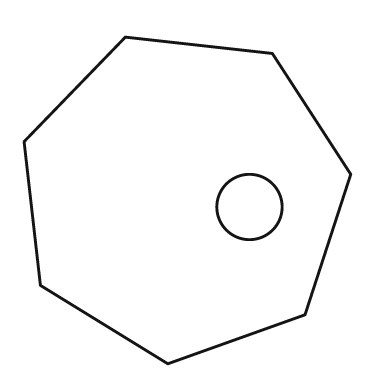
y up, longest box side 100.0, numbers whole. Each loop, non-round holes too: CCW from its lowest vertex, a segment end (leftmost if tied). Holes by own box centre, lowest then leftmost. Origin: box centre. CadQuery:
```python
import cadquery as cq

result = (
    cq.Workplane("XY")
    .moveTo(-6.0, -50.0)
    .lineTo(36.0, -35.0)
    .lineTo(50.0, 8.0)
    .lineTo(26.0, 45.0)
    .lineTo(-19.0, 50.0)
    .lineTo(-50.0, 18.0)
    .lineTo(-45.0, -26.0)
    .close()
    .moveTo(19.0, -2.0)
    .circle(10.0)
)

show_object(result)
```